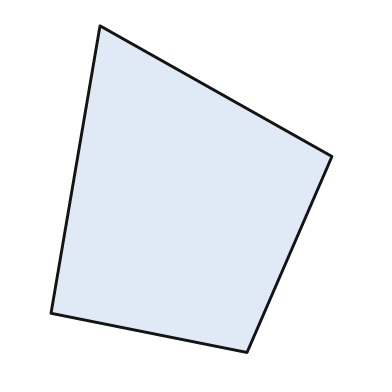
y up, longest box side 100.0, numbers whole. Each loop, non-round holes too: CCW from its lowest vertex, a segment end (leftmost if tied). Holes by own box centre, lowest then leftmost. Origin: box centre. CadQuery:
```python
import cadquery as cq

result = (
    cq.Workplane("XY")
    .moveTo(17.0, -50.0)
    .lineTo(43.0, 10.0)
    .lineTo(-28.0, 50.0)
    .lineTo(-43.0, -38.0)
    .close()
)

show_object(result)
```